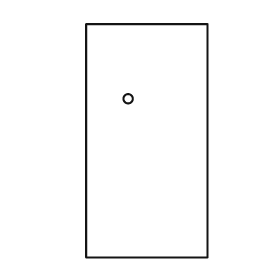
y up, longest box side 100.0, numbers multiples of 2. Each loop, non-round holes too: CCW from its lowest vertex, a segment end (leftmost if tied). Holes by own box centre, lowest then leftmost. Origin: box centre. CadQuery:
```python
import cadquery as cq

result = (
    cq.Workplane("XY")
    .moveTo(-26.0, -50.0)
    .lineTo(26.0, -50.0)
    .lineTo(26.0, 50.0)
    .lineTo(-26.0, 50.0)
    .close()
    .moveTo(-8.0, 18.0)
    .circle(2.0)
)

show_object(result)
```